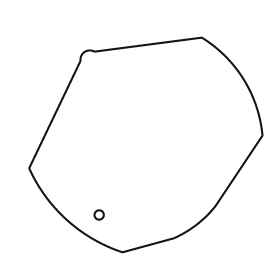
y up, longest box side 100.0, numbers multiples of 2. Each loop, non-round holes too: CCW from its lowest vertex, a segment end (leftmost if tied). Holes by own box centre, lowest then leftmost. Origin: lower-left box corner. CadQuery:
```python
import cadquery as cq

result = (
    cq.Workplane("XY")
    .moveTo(40.0, 0.0)
    .lineTo(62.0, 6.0)
    .threePointArc((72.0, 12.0), (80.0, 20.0))
    .lineTo(100.0, 50.0)
    .threePointArc((92.0, 74.0), (74.0, 92.0))
    .lineTo(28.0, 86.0)
    .threePointArc((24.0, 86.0), (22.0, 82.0))
    .lineTo(0.0, 36.0)
    .threePointArc((16.0, 14.0), (40.0, 0.0))
    .close()
    .moveTo(30.0, 16.0)
    .circle(2.0)
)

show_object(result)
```